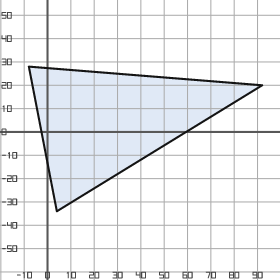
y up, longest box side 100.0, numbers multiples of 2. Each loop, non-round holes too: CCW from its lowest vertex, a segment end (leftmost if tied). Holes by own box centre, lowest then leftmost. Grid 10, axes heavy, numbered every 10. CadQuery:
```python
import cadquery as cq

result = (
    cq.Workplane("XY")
    .moveTo(4.0, -34.0)
    .lineTo(92.0, 20.0)
    .lineTo(-8.0, 28.0)
    .close()
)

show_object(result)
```